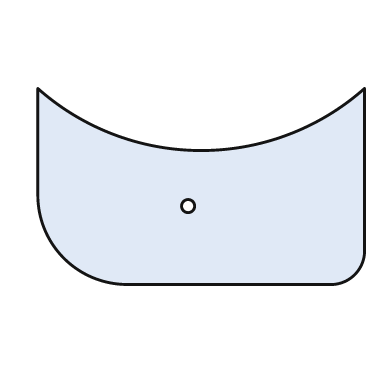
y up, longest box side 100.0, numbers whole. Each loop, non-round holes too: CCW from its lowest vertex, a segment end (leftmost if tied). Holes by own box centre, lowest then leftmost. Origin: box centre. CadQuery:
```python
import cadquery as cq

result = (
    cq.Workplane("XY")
    .moveTo(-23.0, -30.0)
    .lineTo(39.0, -30.0)
    .threePointArc((47.0, -27.0), (50.0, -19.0))
    .lineTo(50.0, 30.0)
    .threePointArc((0.0, 11.0), (-50.0, 30.0))
    .lineTo(-50.0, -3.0)
    .threePointArc((-42.0, -22.0), (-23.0, -30.0))
    .close()
    .moveTo(-4.0, -6.0)
    .circle(2.0)
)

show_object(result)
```